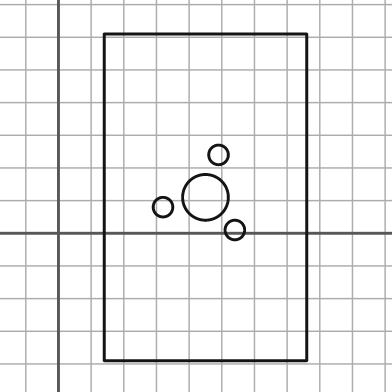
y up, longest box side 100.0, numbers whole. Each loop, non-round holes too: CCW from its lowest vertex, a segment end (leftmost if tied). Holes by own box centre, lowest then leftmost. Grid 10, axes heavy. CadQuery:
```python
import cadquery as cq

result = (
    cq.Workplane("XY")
    .moveTo(14.0, -39.0)
    .lineTo(76.0, -39.0)
    .lineTo(76.0, 61.0)
    .lineTo(14.0, 61.0)
    .close()
    .moveTo(54.0, 1.0)
    .circle(3.0)
    .moveTo(32.0, 8.0)
    .circle(3.0)
    .moveTo(45.0, 11.0)
    .circle(7.0)
    .moveTo(49.0, 24.0)
    .circle(3.0)
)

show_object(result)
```